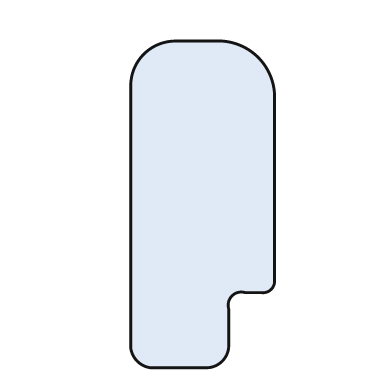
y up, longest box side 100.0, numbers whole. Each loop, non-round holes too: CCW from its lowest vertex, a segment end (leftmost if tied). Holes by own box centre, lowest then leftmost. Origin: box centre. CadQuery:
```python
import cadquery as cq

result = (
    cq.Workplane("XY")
    .moveTo(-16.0, -50.0)
    .lineTo(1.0, -50.0)
    .threePointArc((6.0, -48.0), (8.0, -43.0))
    .lineTo(8.0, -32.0)
    .threePointArc((9.0, -28.0), (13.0, -27.0))
    .lineTo(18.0, -27.0)
    .threePointArc((21.0, -26.0), (22.0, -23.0))
    .lineTo(22.0, 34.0)
    .threePointArc((17.0, 45.0), (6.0, 50.0))
    .lineTo(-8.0, 50.0)
    .threePointArc((-18.0, 46.0), (-22.0, 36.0))
    .lineTo(-22.0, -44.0)
    .threePointArc((-20.0, -48.0), (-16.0, -50.0))
    .close()
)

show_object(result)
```